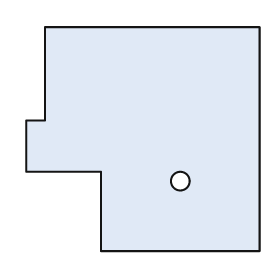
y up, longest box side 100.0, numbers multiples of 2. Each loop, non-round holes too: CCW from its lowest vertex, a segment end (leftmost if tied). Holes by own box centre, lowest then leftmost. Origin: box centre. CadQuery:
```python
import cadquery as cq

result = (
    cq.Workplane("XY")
    .moveTo(-18.0, -48.0)
    .lineTo(50.0, -48.0)
    .lineTo(50.0, 48.0)
    .lineTo(-42.0, 48.0)
    .lineTo(-42.0, 8.0)
    .lineTo(-50.0, 8.0)
    .lineTo(-50.0, -14.0)
    .lineTo(-18.0, -14.0)
    .close()
    .moveTo(16.0, -18.0)
    .circle(4.0)
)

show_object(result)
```